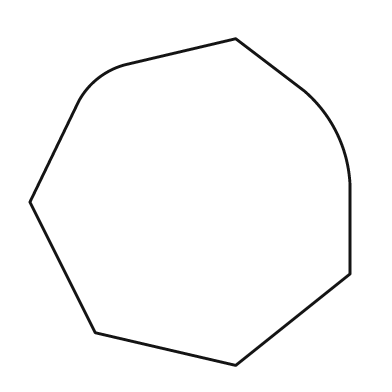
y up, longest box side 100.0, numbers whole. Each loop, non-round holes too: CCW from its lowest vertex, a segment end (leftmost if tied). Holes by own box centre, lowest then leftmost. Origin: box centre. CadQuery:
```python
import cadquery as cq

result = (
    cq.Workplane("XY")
    .moveTo(14.0, -50.0)
    .lineTo(49.0, -22.0)
    .lineTo(49.0, 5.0)
    .threePointArc((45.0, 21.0), (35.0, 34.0))
    .lineTo(14.0, 50.0)
    .lineTo(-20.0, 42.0)
    .threePointArc((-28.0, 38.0), (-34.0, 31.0))
    .lineTo(-49.0, 0.0)
    .lineTo(-29.0, -40.0)
    .close()
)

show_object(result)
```